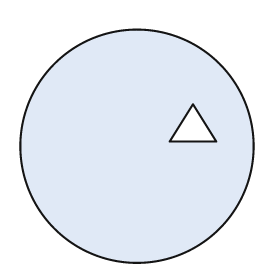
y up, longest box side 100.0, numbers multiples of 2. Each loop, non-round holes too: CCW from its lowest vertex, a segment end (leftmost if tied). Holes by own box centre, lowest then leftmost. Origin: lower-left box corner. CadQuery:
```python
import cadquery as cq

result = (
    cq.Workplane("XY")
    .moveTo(50.0, 50.0)
    .circle(50.0)
    .moveTo(64.0, 52.0)
    .lineTo(84.0, 52.0)
    .lineTo(74.0, 68.0)
    .close()
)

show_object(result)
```